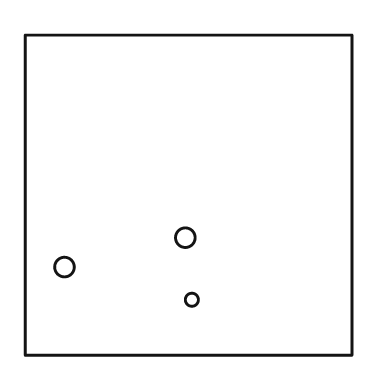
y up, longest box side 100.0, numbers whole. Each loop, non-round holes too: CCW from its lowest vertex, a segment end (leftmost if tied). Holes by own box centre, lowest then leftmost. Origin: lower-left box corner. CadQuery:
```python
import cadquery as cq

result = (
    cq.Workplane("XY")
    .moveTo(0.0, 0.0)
    .lineTo(100.0, 0.0)
    .lineTo(100.0, 98.0)
    .lineTo(0.0, 98.0)
    .close()
    .moveTo(51.0, 17.0)
    .circle(2.0)
    .moveTo(12.0, 27.0)
    .circle(3.0)
    .moveTo(49.0, 36.0)
    .circle(3.0)
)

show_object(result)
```